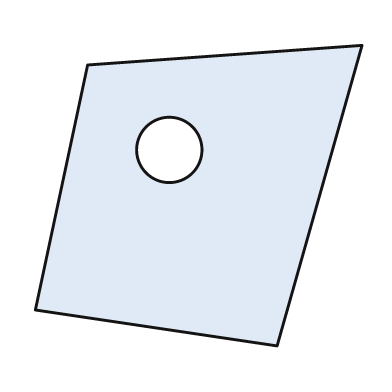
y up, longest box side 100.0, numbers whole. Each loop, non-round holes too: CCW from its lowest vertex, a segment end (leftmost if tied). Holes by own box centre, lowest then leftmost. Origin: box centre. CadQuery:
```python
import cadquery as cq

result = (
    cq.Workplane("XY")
    .moveTo(24.0, -46.0)
    .lineTo(50.0, 46.0)
    .lineTo(-34.0, 40.0)
    .lineTo(-50.0, -35.0)
    .close()
    .moveTo(-9.0, 14.0)
    .circle(10.0)
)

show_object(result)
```